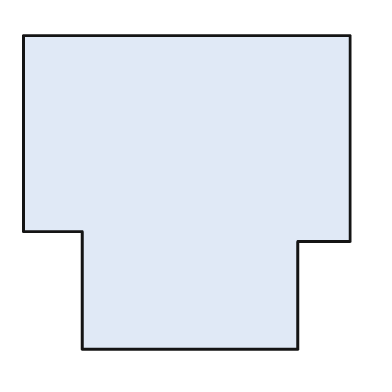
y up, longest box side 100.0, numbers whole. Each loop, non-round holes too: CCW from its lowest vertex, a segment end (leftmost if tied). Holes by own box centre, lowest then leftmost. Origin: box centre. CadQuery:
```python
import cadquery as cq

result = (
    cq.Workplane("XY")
    .moveTo(-32.0, -48.0)
    .lineTo(34.0, -48.0)
    .lineTo(34.0, -15.0)
    .lineTo(50.0, -15.0)
    .lineTo(50.0, 48.0)
    .lineTo(-50.0, 48.0)
    .lineTo(-50.0, -12.0)
    .lineTo(-32.0, -12.0)
    .close()
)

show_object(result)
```